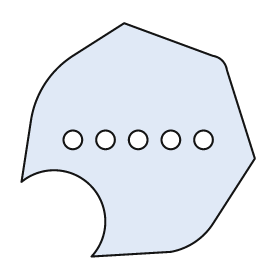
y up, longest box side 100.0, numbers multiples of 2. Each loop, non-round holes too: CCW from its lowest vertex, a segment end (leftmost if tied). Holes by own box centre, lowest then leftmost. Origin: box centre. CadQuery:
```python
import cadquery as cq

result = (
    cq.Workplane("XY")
    .moveTo(-20.0, -50.0)
    .lineTo(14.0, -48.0)
    .threePointArc((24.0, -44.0), (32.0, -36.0))
    .lineTo(50.0, -8.0)
    .lineTo(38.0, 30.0)
    .threePointArc((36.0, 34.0), (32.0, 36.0))
    .lineTo(-6.0, 50.0)
    .lineTo(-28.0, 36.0)
    .threePointArc((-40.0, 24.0), (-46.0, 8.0))
    .lineTo(-50.0, -18.0)
    .threePointArc((-20.0, -20.0), (-20.0, -50.0))
    .close()
    .moveTo(-28.0, 0.0)
    .circle(4.0)
    .moveTo(-14.0, 0.0)
    .circle(4.0)
    .moveTo(0.0, 0.0)
    .circle(4.0)
    .moveTo(14.0, 0.0)
    .circle(4.0)
    .moveTo(28.0, 0.0)
    .circle(4.0)
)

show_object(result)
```